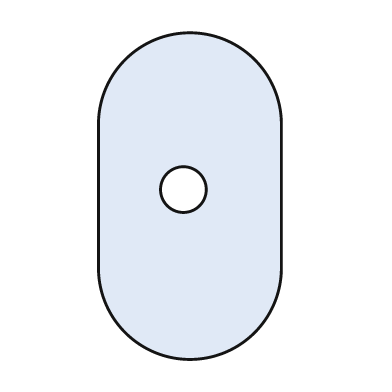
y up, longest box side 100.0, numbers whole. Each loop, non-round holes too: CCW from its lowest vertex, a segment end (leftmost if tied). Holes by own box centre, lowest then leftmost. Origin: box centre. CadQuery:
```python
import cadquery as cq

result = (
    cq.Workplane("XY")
    .moveTo(-28.0, -22.0)
    .threePointArc((0.0, -50.0), (28.0, -22.0))
    .lineTo(28.0, 22.0)
    .threePointArc((0.0, 50.0), (-28.0, 22.0))
    .close()
    .moveTo(-2.0, 2.0)
    .circle(7.0)
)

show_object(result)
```